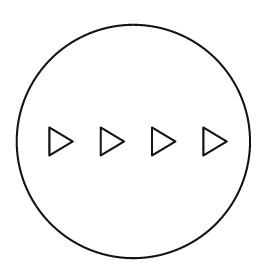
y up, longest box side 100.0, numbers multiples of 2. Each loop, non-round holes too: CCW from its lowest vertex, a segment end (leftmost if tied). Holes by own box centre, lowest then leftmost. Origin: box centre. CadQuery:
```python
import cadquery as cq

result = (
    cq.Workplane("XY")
    .moveTo(0.0, 0.0)
    .circle(50.0)
    .moveTo(-36.0, -6.0)
    .lineTo(-26.0, 0.0)
    .lineTo(-36.0, 6.0)
    .close()
    .moveTo(-14.0, -6.0)
    .lineTo(-4.0, 0.0)
    .lineTo(-14.0, 6.0)
    .close()
    .moveTo(8.0, -6.0)
    .lineTo(18.0, 0.0)
    .lineTo(8.0, 6.0)
    .close()
    .moveTo(30.0, -6.0)
    .lineTo(40.0, 0.0)
    .lineTo(30.0, 6.0)
    .close()
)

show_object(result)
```